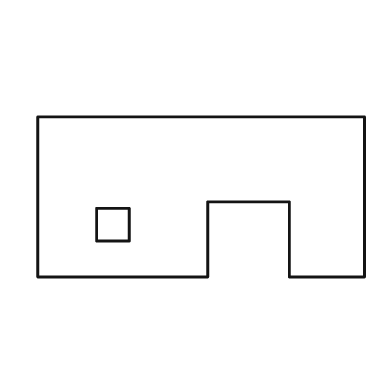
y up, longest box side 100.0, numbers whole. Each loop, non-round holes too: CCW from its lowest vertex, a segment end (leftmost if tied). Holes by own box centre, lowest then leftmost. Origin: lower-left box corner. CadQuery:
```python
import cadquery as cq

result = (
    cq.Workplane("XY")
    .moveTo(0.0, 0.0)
    .lineTo(52.0, 0.0)
    .lineTo(52.0, 23.0)
    .lineTo(77.0, 23.0)
    .lineTo(77.0, 0.0)
    .lineTo(100.0, 0.0)
    .lineTo(100.0, 49.0)
    .lineTo(0.0, 49.0)
    .close()
    .moveTo(18.0, 11.0)
    .lineTo(28.0, 11.0)
    .lineTo(28.0, 21.0)
    .lineTo(18.0, 21.0)
    .close()
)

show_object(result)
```